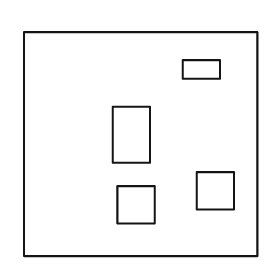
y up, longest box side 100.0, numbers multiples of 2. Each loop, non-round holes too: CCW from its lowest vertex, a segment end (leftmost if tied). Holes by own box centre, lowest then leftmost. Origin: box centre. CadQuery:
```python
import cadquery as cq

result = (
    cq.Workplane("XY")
    .moveTo(-50.0, -48.0)
    .lineTo(50.0, -48.0)
    .lineTo(50.0, 48.0)
    .lineTo(-50.0, 48.0)
    .close()
    .moveTo(-10.0, -34.0)
    .lineTo(6.0, -34.0)
    .lineTo(6.0, -18.0)
    .lineTo(-10.0, -18.0)
    .close()
    .moveTo(24.0, -28.0)
    .lineTo(40.0, -28.0)
    .lineTo(40.0, -12.0)
    .lineTo(24.0, -12.0)
    .close()
    .moveTo(-12.0, -8.0)
    .lineTo(4.0, -8.0)
    .lineTo(4.0, 16.0)
    .lineTo(-12.0, 16.0)
    .close()
    .moveTo(18.0, 28.0)
    .lineTo(34.0, 28.0)
    .lineTo(34.0, 36.0)
    .lineTo(18.0, 36.0)
    .close()
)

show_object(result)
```